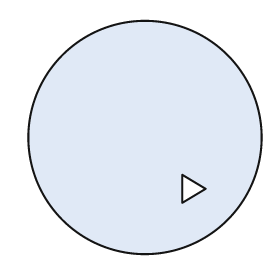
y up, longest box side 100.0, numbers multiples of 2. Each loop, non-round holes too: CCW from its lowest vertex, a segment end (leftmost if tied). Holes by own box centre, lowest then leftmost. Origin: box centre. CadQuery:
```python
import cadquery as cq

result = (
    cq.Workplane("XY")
    .moveTo(0.0, 0.0)
    .circle(50.0)
    .moveTo(16.0, -28.0)
    .lineTo(26.0, -22.0)
    .lineTo(16.0, -16.0)
    .close()
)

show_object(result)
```